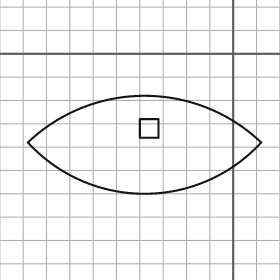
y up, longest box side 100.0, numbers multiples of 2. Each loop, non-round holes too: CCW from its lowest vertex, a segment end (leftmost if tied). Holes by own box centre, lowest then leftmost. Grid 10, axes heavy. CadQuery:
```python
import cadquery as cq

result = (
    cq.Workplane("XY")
    .moveTo(-88.0, -38.0)
    .threePointArc((-38.0, -60.0), (12.0, -38.0))
    .threePointArc((-38.0, -18.0), (-88.0, -38.0))
    .close()
    .moveTo(-40.0, -36.0)
    .lineTo(-32.0, -36.0)
    .lineTo(-32.0, -28.0)
    .lineTo(-40.0, -28.0)
    .close()
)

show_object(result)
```